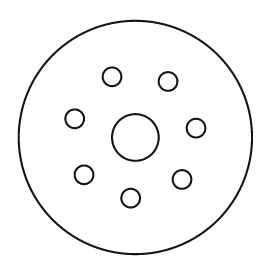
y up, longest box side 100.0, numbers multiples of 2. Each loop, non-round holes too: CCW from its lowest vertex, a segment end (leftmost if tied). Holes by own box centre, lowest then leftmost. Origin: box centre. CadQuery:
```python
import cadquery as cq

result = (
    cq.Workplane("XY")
    .moveTo(0.0, 0.0)
    .circle(50.0)
    .moveTo(-2.0, -26.0)
    .circle(4.0)
    .moveTo(20.0, -18.0)
    .circle(4.0)
    .moveTo(-22.0, -16.0)
    .circle(4.0)
    .moveTo(0.0, 0.0)
    .circle(10.0)
    .moveTo(26.0, 4.0)
    .circle(4.0)
    .moveTo(-26.0, 8.0)
    .circle(4.0)
    .moveTo(14.0, 24.0)
    .circle(4.0)
    .moveTo(-10.0, 26.0)
    .circle(4.0)
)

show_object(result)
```